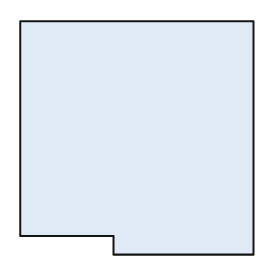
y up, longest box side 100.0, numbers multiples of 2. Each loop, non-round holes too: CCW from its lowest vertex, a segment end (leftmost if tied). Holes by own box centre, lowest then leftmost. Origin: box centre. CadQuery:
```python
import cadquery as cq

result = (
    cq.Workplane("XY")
    .moveTo(-10.0, -50.0)
    .lineTo(50.0, -50.0)
    .lineTo(50.0, 50.0)
    .lineTo(-50.0, 50.0)
    .lineTo(-50.0, -42.0)
    .lineTo(-10.0, -42.0)
    .close()
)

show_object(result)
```